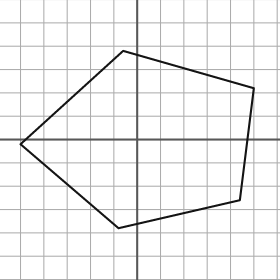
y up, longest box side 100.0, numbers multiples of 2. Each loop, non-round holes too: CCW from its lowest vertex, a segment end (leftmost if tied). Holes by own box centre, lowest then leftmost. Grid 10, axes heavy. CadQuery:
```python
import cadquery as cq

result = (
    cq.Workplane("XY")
    .moveTo(-8.0, -38.0)
    .lineTo(44.0, -26.0)
    .lineTo(50.0, 22.0)
    .lineTo(-6.0, 38.0)
    .lineTo(-50.0, -2.0)
    .close()
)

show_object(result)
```